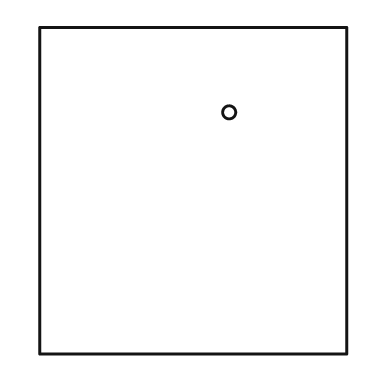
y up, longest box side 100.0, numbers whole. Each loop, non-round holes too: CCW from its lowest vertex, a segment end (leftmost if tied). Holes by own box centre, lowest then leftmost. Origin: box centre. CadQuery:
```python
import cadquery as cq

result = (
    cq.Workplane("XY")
    .moveTo(-47.0, -50.0)
    .lineTo(47.0, -50.0)
    .lineTo(47.0, 50.0)
    .lineTo(-47.0, 50.0)
    .close()
    .moveTo(11.0, 24.0)
    .circle(2.0)
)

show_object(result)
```